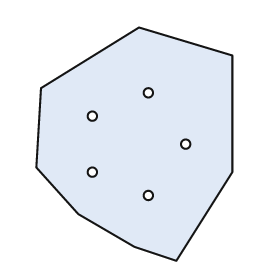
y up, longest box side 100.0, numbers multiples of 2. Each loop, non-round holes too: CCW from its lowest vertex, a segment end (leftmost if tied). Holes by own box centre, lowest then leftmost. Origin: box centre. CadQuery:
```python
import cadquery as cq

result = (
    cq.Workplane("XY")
    .moveTo(18.0, -50.0)
    .lineTo(42.0, -12.0)
    .lineTo(42.0, 38.0)
    .lineTo(2.0, 50.0)
    .lineTo(-40.0, 24.0)
    .lineTo(-42.0, -10.0)
    .lineTo(-24.0, -30.0)
    .lineTo(0.0, -44.0)
    .close()
    .moveTo(6.0, -22.0)
    .circle(2.0)
    .moveTo(-18.0, -12.0)
    .circle(2.0)
    .moveTo(22.0, 0.0)
    .circle(2.0)
    .moveTo(-18.0, 12.0)
    .circle(2.0)
    .moveTo(6.0, 22.0)
    .circle(2.0)
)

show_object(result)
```